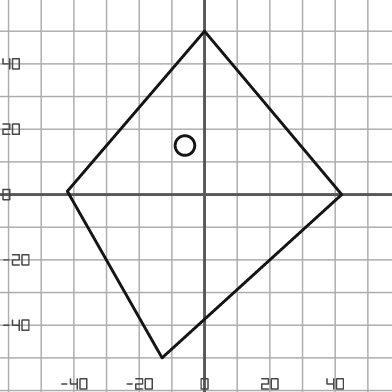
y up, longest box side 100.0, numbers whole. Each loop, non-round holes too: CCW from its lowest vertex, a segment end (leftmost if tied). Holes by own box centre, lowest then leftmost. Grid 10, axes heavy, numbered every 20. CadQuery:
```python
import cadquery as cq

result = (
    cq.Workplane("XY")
    .moveTo(-13.0, -50.0)
    .lineTo(42.0, 0.0)
    .lineTo(0.0, 50.0)
    .lineTo(-42.0, 1.0)
    .close()
    .moveTo(-6.0, 15.0)
    .circle(3.0)
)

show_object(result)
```